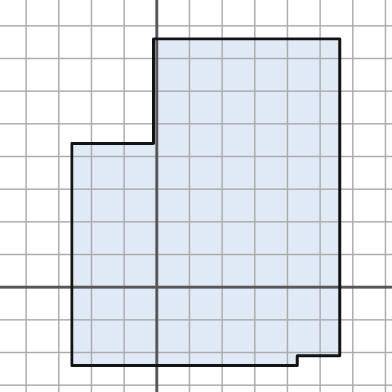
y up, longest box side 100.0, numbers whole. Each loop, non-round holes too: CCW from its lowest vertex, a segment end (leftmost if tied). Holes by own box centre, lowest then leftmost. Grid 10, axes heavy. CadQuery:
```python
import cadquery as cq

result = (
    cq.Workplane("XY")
    .moveTo(-26.0, -24.0)
    .lineTo(43.0, -24.0)
    .lineTo(43.0, -21.0)
    .lineTo(56.0, -21.0)
    .lineTo(56.0, 76.0)
    .lineTo(-1.0, 76.0)
    .lineTo(-1.0, 44.0)
    .lineTo(-26.0, 44.0)
    .close()
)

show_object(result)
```